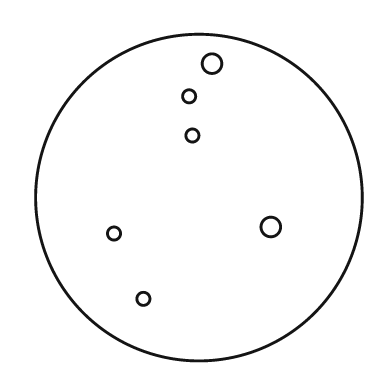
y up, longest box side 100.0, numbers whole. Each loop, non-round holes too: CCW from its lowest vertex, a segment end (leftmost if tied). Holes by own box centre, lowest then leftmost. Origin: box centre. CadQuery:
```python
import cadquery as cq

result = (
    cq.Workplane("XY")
    .moveTo(0.0, 0.0)
    .circle(50.0)
    .moveTo(-17.0, -31.0)
    .circle(2.0)
    .moveTo(-26.0, -11.0)
    .circle(2.0)
    .moveTo(22.0, -9.0)
    .circle(3.0)
    .moveTo(-2.0, 19.0)
    .circle(2.0)
    .moveTo(-3.0, 31.0)
    .circle(2.0)
    .moveTo(4.0, 41.0)
    .circle(3.0)
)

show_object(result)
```